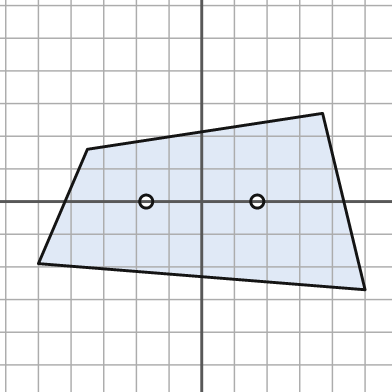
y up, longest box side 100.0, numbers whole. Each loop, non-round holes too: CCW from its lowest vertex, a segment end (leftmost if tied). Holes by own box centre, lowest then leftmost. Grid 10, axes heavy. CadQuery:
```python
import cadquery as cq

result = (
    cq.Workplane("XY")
    .moveTo(50.0, -27.0)
    .lineTo(37.0, 27.0)
    .lineTo(-35.0, 16.0)
    .lineTo(-50.0, -19.0)
    .close()
    .moveTo(-17.0, 0.0)
    .circle(2.0)
    .moveTo(17.0, 0.0)
    .circle(2.0)
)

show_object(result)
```